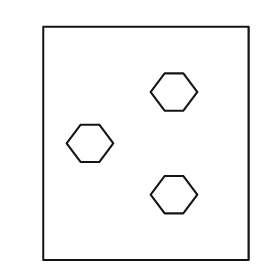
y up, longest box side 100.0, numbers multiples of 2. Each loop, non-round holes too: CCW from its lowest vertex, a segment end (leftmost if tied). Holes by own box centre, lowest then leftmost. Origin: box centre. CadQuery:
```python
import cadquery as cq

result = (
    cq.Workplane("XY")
    .moveTo(-44.0, -50.0)
    .lineTo(44.0, -50.0)
    .lineTo(44.0, 50.0)
    .lineTo(-44.0, 50.0)
    .close()
    .moveTo(8.0, -30.0)
    .lineTo(16.0, -30.0)
    .lineTo(22.0, -22.0)
    .lineTo(16.0, -14.0)
    .lineTo(8.0, -14.0)
    .lineTo(2.0, -22.0)
    .close()
    .moveTo(-28.0, -8.0)
    .lineTo(-20.0, -8.0)
    .lineTo(-14.0, 0.0)
    .lineTo(-20.0, 8.0)
    .lineTo(-28.0, 8.0)
    .lineTo(-34.0, 0.0)
    .close()
    .moveTo(8.0, 14.0)
    .lineTo(16.0, 14.0)
    .lineTo(22.0, 22.0)
    .lineTo(16.0, 30.0)
    .lineTo(8.0, 30.0)
    .lineTo(2.0, 22.0)
    .close()
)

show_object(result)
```